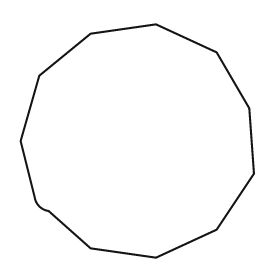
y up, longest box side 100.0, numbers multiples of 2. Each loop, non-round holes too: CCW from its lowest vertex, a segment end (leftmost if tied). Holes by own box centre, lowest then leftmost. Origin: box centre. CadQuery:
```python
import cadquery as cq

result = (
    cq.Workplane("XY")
    .moveTo(8.0, -50.0)
    .lineTo(34.0, -38.0)
    .lineTo(50.0, -14.0)
    .lineTo(48.0, 14.0)
    .lineTo(34.0, 38.0)
    .lineTo(8.0, 50.0)
    .lineTo(-20.0, 46.0)
    .lineTo(-42.0, 28.0)
    .lineTo(-50.0, 0.0)
    .lineTo(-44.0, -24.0)
    .threePointArc((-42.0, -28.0), (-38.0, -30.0))
    .lineTo(-20.0, -46.0)
    .close()
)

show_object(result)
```